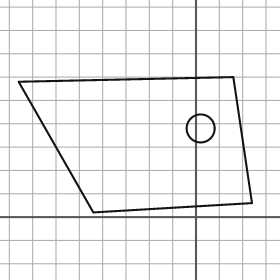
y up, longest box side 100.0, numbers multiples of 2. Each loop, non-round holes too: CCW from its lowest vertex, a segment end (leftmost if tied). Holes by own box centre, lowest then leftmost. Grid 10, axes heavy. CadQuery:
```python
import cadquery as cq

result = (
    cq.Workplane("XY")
    .moveTo(-44.0, 2.0)
    .lineTo(24.0, 6.0)
    .lineTo(16.0, 60.0)
    .lineTo(-76.0, 58.0)
    .close()
    .moveTo(2.0, 38.0)
    .circle(6.0)
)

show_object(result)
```